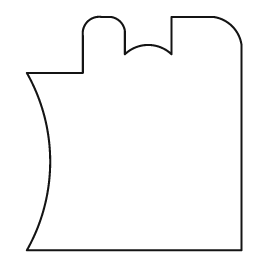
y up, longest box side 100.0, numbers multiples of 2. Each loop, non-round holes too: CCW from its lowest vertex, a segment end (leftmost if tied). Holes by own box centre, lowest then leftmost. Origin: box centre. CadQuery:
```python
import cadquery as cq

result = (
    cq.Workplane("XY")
    .moveTo(-46.0, -50.0)
    .lineTo(46.0, -50.0)
    .lineTo(46.0, 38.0)
    .threePointArc((42.0, 46.0), (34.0, 50.0))
    .lineTo(16.0, 50.0)
    .lineTo(16.0, 34.0)
    .threePointArc((6.0, 38.0), (-4.0, 34.0))
    .lineTo(-4.0, 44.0)
    .threePointArc((-6.0, 48.0), (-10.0, 50.0))
    .lineTo(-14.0, 50.0)
    .threePointArc((-20.0, 48.0), (-22.0, 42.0))
    .lineTo(-22.0, 26.0)
    .lineTo(-46.0, 26.0)
    .threePointArc((-36.0, -12.0), (-46.0, -50.0))
    .close()
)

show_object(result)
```